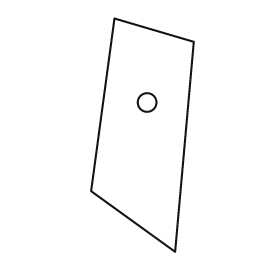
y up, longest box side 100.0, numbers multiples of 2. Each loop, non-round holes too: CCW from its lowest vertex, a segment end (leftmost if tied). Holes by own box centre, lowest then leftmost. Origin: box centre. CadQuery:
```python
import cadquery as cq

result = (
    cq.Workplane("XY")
    .moveTo(14.0, -50.0)
    .lineTo(22.0, 40.0)
    .lineTo(-12.0, 50.0)
    .lineTo(-22.0, -24.0)
    .close()
    .moveTo(2.0, 14.0)
    .circle(4.0)
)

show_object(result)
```